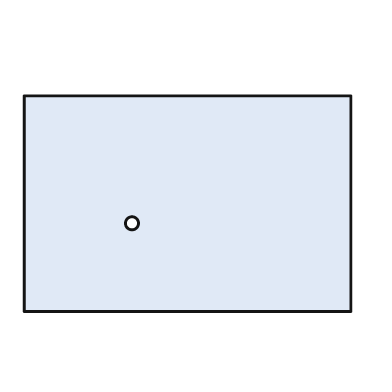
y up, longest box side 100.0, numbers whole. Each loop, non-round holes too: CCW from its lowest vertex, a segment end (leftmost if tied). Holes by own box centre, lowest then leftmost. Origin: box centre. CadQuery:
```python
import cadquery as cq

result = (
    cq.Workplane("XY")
    .moveTo(-50.0, -33.0)
    .lineTo(50.0, -33.0)
    .lineTo(50.0, 33.0)
    .lineTo(-50.0, 33.0)
    .close()
    .moveTo(-17.0, -6.0)
    .circle(2.0)
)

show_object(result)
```